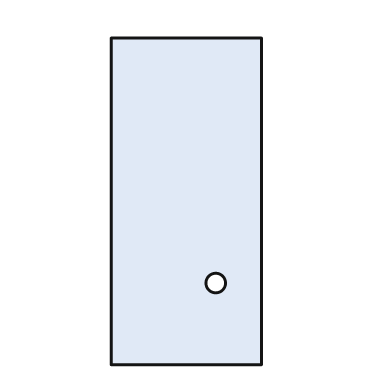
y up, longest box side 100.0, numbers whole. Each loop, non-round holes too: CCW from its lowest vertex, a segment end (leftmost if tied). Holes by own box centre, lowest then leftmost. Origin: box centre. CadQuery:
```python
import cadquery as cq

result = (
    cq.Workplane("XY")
    .moveTo(-23.0, -50.0)
    .lineTo(23.0, -50.0)
    .lineTo(23.0, 50.0)
    .lineTo(-23.0, 50.0)
    .close()
    .moveTo(9.0, -25.0)
    .circle(3.0)
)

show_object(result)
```